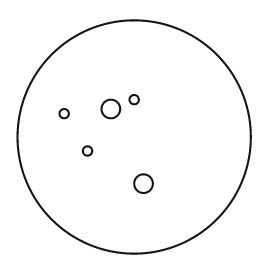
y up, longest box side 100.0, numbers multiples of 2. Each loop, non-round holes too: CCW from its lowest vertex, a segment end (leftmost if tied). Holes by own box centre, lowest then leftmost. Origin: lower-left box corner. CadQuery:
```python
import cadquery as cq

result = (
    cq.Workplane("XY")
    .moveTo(50.0, 50.0)
    .circle(50.0)
    .moveTo(54.0, 30.0)
    .circle(4.0)
    .moveTo(30.0, 44.0)
    .circle(2.0)
    .moveTo(20.0, 60.0)
    .circle(2.0)
    .moveTo(40.0, 62.0)
    .circle(4.0)
    .moveTo(50.0, 66.0)
    .circle(2.0)
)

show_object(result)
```